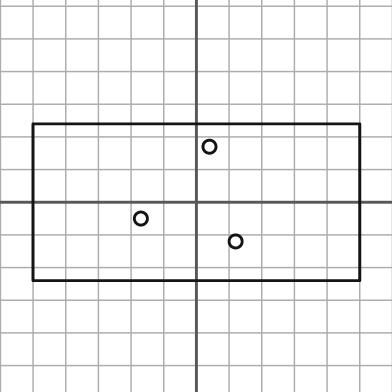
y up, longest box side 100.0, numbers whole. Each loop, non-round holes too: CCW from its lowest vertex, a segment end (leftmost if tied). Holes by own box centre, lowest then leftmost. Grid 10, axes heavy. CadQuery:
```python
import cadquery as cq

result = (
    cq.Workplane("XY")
    .moveTo(-50.0, -24.0)
    .lineTo(50.0, -24.0)
    .lineTo(50.0, 24.0)
    .lineTo(-50.0, 24.0)
    .close()
    .moveTo(12.0, -12.0)
    .circle(2.0)
    .moveTo(-17.0, -5.0)
    .circle(2.0)
    .moveTo(4.0, 17.0)
    .circle(2.0)
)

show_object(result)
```